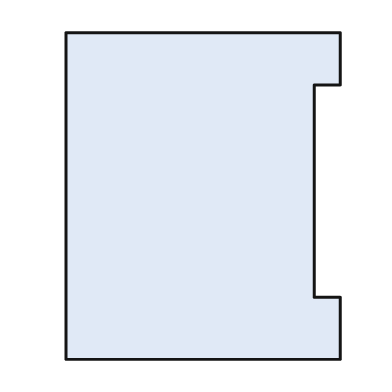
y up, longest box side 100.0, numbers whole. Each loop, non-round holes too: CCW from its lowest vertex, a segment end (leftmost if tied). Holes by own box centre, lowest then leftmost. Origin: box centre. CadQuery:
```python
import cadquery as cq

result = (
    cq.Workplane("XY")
    .moveTo(-42.0, -50.0)
    .lineTo(42.0, -50.0)
    .lineTo(42.0, -31.0)
    .lineTo(34.0, -31.0)
    .lineTo(34.0, 34.0)
    .lineTo(42.0, 34.0)
    .lineTo(42.0, 50.0)
    .lineTo(-42.0, 50.0)
    .close()
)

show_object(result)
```